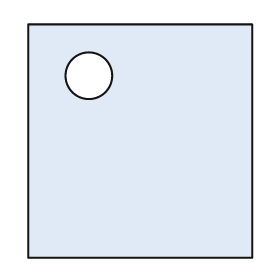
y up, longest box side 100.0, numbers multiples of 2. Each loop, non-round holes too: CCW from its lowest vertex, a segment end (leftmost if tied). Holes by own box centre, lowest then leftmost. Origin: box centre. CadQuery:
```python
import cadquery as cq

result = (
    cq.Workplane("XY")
    .moveTo(-48.0, -50.0)
    .lineTo(48.0, -50.0)
    .lineTo(48.0, 50.0)
    .lineTo(-48.0, 50.0)
    .close()
    .moveTo(-22.0, 28.0)
    .circle(10.0)
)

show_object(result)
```